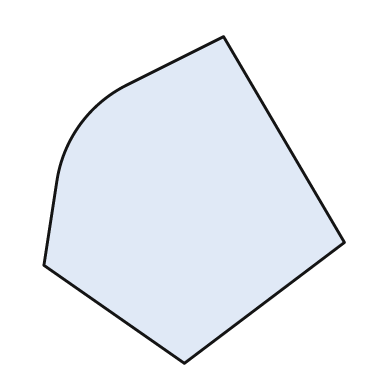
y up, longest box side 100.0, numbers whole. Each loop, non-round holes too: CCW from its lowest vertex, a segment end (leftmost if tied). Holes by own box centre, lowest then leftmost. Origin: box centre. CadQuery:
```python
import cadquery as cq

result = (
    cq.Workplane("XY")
    .moveTo(-3.0, -50.0)
    .lineTo(46.0, -13.0)
    .lineTo(9.0, 50.0)
    .lineTo(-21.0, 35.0)
    .threePointArc((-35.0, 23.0), (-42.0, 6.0))
    .lineTo(-46.0, -20.0)
    .close()
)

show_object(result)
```